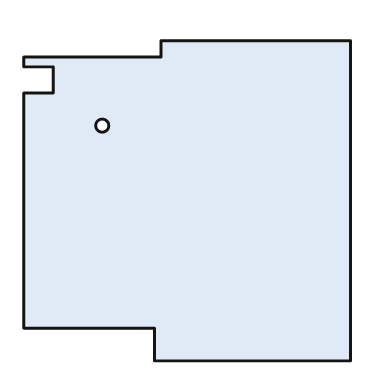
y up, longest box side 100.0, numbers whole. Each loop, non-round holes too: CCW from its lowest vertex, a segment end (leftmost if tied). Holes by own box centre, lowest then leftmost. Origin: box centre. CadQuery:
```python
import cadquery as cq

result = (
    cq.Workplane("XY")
    .moveTo(-10.0, -49.0)
    .lineTo(50.0, -49.0)
    .lineTo(50.0, 49.0)
    .lineTo(-8.0, 49.0)
    .lineTo(-8.0, 44.0)
    .lineTo(-50.0, 44.0)
    .lineTo(-50.0, 41.0)
    .lineTo(-41.0, 41.0)
    .lineTo(-41.0, 33.0)
    .lineTo(-50.0, 33.0)
    .lineTo(-50.0, -39.0)
    .lineTo(-10.0, -39.0)
    .close()
    .moveTo(-26.0, 23.0)
    .circle(2.0)
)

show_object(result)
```